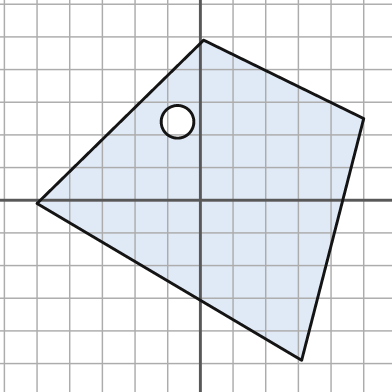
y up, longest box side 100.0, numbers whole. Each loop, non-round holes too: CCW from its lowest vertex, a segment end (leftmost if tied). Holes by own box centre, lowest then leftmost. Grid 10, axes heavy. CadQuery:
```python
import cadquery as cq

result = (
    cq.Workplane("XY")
    .moveTo(31.0, -49.0)
    .lineTo(50.0, 25.0)
    .lineTo(1.0, 49.0)
    .lineTo(-50.0, -1.0)
    .close()
    .moveTo(-7.0, 24.0)
    .circle(5.0)
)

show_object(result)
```